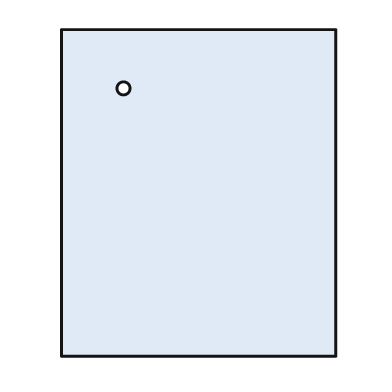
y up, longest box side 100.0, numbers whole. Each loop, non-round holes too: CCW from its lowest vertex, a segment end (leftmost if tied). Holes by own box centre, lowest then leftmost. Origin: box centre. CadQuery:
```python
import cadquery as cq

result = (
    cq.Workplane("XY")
    .moveTo(-42.0, -50.0)
    .lineTo(42.0, -50.0)
    .lineTo(42.0, 50.0)
    .lineTo(-42.0, 50.0)
    .close()
    .moveTo(-23.0, 32.0)
    .circle(2.0)
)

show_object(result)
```